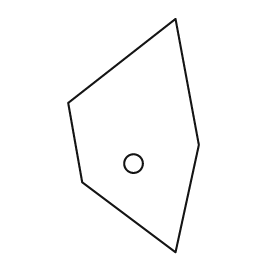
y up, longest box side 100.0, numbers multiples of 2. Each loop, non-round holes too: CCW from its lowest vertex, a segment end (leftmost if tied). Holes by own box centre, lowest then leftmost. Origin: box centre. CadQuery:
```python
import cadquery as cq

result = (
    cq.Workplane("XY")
    .moveTo(18.0, -50.0)
    .lineTo(28.0, -4.0)
    .lineTo(18.0, 50.0)
    .lineTo(-28.0, 14.0)
    .lineTo(-22.0, -20.0)
    .close()
    .moveTo(0.0, -12.0)
    .circle(4.0)
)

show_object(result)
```